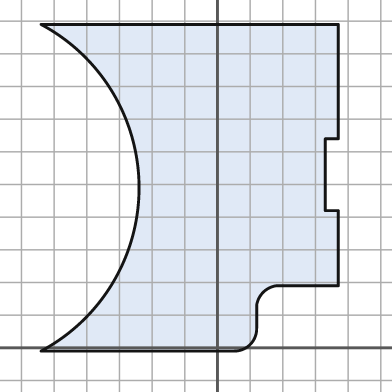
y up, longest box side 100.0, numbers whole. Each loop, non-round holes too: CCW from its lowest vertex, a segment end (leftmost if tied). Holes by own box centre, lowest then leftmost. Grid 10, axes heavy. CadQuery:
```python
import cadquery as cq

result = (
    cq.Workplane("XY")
    .moveTo(-54.0, -1.0)
    .lineTo(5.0, -1.0)
    .threePointArc((10.0, 1.0), (12.0, 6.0))
    .lineTo(12.0, 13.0)
    .threePointArc((14.0, 17.0), (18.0, 19.0))
    .lineTo(37.0, 19.0)
    .lineTo(37.0, 42.0)
    .lineTo(33.0, 42.0)
    .lineTo(33.0, 64.0)
    .lineTo(37.0, 64.0)
    .lineTo(37.0, 99.0)
    .lineTo(-54.0, 99.0)
    .threePointArc((-24.0, 49.0), (-54.0, -1.0))
    .close()
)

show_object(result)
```